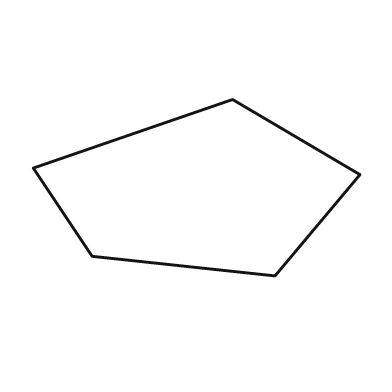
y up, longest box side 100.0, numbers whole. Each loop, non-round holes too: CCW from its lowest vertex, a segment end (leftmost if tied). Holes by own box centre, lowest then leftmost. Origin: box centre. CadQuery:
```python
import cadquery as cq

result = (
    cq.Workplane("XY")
    .moveTo(24.0, -27.0)
    .lineTo(50.0, 4.0)
    .lineTo(11.0, 27.0)
    .lineTo(-50.0, 6.0)
    .lineTo(-32.0, -21.0)
    .close()
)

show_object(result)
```